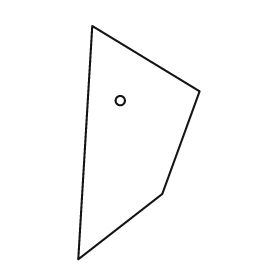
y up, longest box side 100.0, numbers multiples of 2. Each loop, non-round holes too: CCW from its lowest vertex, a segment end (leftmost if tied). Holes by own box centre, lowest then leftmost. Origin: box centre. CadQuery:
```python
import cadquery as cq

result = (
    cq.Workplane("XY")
    .moveTo(-26.0, -50.0)
    .lineTo(10.0, -22.0)
    .lineTo(26.0, 22.0)
    .lineTo(-20.0, 50.0)
    .close()
    .moveTo(-8.0, 18.0)
    .circle(2.0)
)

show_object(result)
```